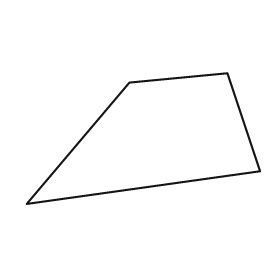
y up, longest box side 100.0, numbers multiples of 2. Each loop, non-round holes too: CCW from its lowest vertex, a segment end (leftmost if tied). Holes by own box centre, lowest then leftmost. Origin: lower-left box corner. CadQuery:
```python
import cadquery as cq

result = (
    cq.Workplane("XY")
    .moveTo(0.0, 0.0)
    .lineTo(100.0, 14.0)
    .lineTo(86.0, 56.0)
    .lineTo(44.0, 52.0)
    .close()
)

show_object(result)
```